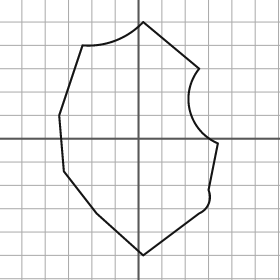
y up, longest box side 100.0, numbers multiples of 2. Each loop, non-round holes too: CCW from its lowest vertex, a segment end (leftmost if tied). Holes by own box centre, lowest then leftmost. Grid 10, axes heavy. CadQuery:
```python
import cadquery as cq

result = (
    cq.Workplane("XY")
    .moveTo(2.0, -50.0)
    .lineTo(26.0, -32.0)
    .threePointArc((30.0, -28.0), (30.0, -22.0))
    .lineTo(34.0, -2.0)
    .threePointArc((22.0, 12.0), (26.0, 30.0))
    .lineTo(2.0, 50.0)
    .threePointArc((-10.0, 42.0), (-24.0, 40.0))
    .lineTo(-34.0, 10.0)
    .lineTo(-32.0, -14.0)
    .lineTo(-18.0, -32.0)
    .close()
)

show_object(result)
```